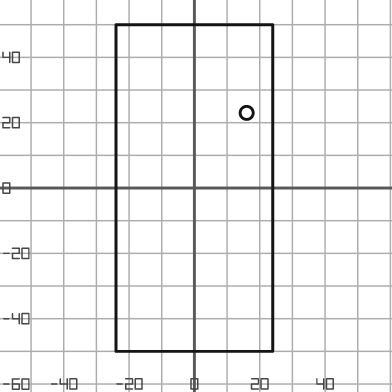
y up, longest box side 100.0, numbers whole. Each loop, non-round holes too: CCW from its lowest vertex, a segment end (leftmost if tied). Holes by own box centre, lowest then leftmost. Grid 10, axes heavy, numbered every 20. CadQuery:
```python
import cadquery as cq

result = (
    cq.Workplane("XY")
    .moveTo(-24.0, -50.0)
    .lineTo(24.0, -50.0)
    .lineTo(24.0, 50.0)
    .lineTo(-24.0, 50.0)
    .close()
    .moveTo(16.0, 23.0)
    .circle(2.0)
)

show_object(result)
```